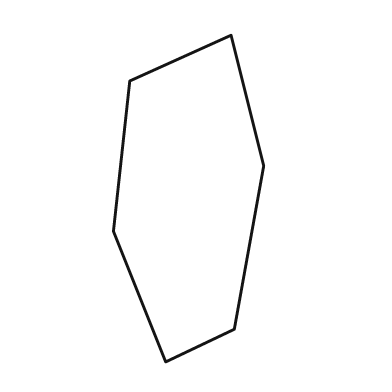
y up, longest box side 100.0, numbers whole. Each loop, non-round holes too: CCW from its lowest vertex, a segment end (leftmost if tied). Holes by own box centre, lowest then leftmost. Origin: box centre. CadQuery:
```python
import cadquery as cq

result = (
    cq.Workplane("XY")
    .moveTo(-7.0, -50.0)
    .lineTo(14.0, -40.0)
    .lineTo(23.0, 10.0)
    .lineTo(13.0, 50.0)
    .lineTo(-18.0, 36.0)
    .lineTo(-23.0, -10.0)
    .close()
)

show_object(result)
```